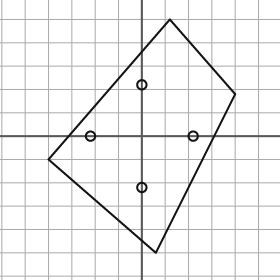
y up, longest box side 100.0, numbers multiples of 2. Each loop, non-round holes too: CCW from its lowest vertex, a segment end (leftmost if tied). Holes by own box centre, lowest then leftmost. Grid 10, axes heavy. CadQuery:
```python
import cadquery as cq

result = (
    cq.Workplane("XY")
    .moveTo(6.0, -50.0)
    .lineTo(40.0, 18.0)
    .lineTo(12.0, 50.0)
    .lineTo(-40.0, -10.0)
    .close()
    .moveTo(0.0, -22.0)
    .circle(2.0)
    .moveTo(-22.0, 0.0)
    .circle(2.0)
    .moveTo(22.0, 0.0)
    .circle(2.0)
    .moveTo(0.0, 22.0)
    .circle(2.0)
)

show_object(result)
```